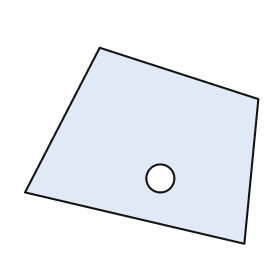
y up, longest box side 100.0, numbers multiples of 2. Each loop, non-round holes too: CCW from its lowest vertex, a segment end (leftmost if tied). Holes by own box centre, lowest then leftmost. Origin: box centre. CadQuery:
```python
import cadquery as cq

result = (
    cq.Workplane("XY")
    .moveTo(44.0, -42.0)
    .lineTo(50.0, 20.0)
    .lineTo(-18.0, 42.0)
    .lineTo(-50.0, -20.0)
    .close()
    .moveTo(8.0, -14.0)
    .circle(6.0)
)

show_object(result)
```